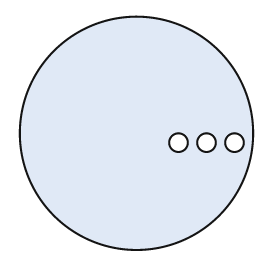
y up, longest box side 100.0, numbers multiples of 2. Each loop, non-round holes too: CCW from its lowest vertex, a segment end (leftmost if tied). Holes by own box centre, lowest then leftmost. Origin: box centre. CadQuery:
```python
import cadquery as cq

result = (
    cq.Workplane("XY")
    .moveTo(0.0, 0.0)
    .circle(50.0)
    .moveTo(18.0, -4.0)
    .circle(4.0)
    .moveTo(30.0, -4.0)
    .circle(4.0)
    .moveTo(42.0, -4.0)
    .circle(4.0)
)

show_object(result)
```